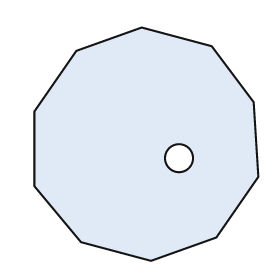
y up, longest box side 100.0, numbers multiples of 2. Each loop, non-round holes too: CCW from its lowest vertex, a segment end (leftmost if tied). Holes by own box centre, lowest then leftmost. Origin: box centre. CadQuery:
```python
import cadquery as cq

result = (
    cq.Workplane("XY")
    .moveTo(2.0, -50.0)
    .lineTo(30.0, -40.0)
    .lineTo(48.0, -14.0)
    .lineTo(46.0, 18.0)
    .lineTo(28.0, 42.0)
    .lineTo(-2.0, 50.0)
    .lineTo(-30.0, 40.0)
    .lineTo(-48.0, 14.0)
    .lineTo(-48.0, -18.0)
    .lineTo(-28.0, -42.0)
    .close()
    .moveTo(14.0, -6.0)
    .circle(6.0)
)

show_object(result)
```